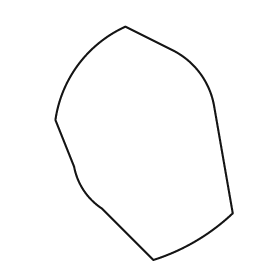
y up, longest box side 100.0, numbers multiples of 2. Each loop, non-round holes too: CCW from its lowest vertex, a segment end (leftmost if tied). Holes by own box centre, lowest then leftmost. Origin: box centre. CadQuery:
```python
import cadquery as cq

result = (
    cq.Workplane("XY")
    .moveTo(4.0, -50.0)
    .threePointArc((22.0, -42.0), (38.0, -30.0))
    .lineTo(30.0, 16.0)
    .threePointArc((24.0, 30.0), (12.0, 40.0))
    .lineTo(-8.0, 50.0)
    .threePointArc((-28.0, 34.0), (-38.0, 10.0))
    .lineTo(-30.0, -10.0)
    .threePointArc((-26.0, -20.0), (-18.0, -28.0))
    .close()
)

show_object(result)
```